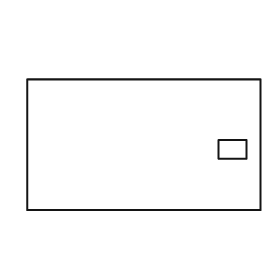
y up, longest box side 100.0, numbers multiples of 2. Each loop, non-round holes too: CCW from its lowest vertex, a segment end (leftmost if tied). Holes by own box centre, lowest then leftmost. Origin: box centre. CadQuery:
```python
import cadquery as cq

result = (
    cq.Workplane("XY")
    .moveTo(-50.0, -28.0)
    .lineTo(50.0, -28.0)
    .lineTo(50.0, 28.0)
    .lineTo(-50.0, 28.0)
    .close()
    .moveTo(32.0, -6.0)
    .lineTo(44.0, -6.0)
    .lineTo(44.0, 2.0)
    .lineTo(32.0, 2.0)
    .close()
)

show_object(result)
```